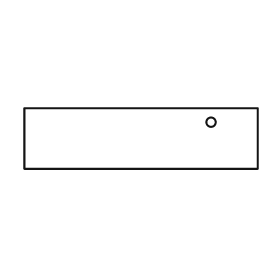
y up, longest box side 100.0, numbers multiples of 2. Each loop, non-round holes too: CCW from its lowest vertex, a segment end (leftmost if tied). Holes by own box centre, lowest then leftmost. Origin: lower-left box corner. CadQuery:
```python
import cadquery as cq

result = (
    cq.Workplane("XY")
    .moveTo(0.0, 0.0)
    .lineTo(100.0, 0.0)
    .lineTo(100.0, 26.0)
    .lineTo(0.0, 26.0)
    .close()
    .moveTo(80.0, 20.0)
    .circle(2.0)
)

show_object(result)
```